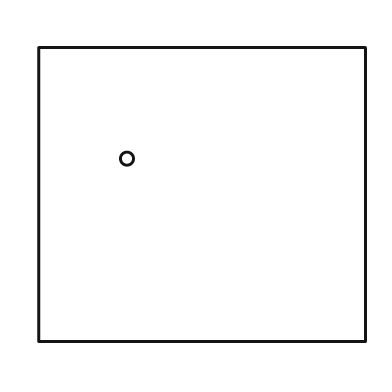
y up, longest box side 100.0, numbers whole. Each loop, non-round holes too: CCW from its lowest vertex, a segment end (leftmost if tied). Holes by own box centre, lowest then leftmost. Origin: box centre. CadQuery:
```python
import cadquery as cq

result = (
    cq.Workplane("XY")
    .moveTo(-50.0, -45.0)
    .lineTo(50.0, -45.0)
    .lineTo(50.0, 45.0)
    .lineTo(-50.0, 45.0)
    .close()
    .moveTo(-23.0, 11.0)
    .circle(2.0)
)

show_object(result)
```